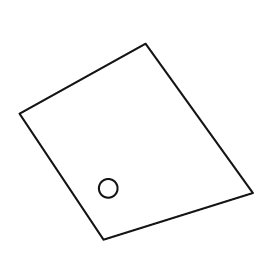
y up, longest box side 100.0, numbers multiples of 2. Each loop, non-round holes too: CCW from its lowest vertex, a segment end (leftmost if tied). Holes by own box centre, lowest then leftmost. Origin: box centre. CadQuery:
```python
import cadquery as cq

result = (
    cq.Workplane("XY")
    .moveTo(-14.0, -42.0)
    .lineTo(50.0, -22.0)
    .lineTo(4.0, 42.0)
    .lineTo(-50.0, 12.0)
    .close()
    .moveTo(-12.0, -20.0)
    .circle(4.0)
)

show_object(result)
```